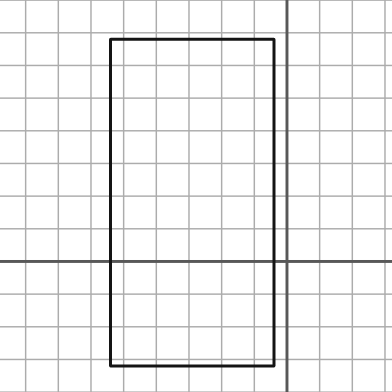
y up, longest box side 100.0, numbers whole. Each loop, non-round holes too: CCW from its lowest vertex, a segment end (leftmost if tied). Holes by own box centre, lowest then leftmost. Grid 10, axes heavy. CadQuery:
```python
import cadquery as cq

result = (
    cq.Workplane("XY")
    .moveTo(-54.0, -32.0)
    .lineTo(-4.0, -32.0)
    .lineTo(-4.0, 68.0)
    .lineTo(-54.0, 68.0)
    .close()
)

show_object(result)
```